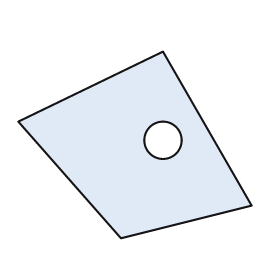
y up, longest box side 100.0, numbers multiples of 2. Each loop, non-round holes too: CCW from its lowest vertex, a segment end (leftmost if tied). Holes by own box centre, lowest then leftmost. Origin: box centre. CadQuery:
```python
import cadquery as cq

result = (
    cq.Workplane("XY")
    .moveTo(-6.0, -40.0)
    .lineTo(50.0, -26.0)
    .lineTo(12.0, 40.0)
    .lineTo(-50.0, 10.0)
    .close()
    .moveTo(12.0, 2.0)
    .circle(8.0)
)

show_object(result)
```